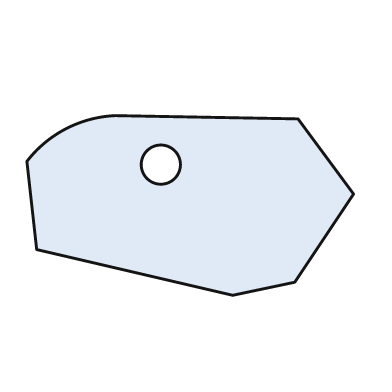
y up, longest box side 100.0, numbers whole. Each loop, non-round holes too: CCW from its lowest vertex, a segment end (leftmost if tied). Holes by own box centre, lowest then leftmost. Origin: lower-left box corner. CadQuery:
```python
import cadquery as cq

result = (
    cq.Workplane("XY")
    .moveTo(63.0, 0.0)
    .lineTo(82.0, 4.0)
    .lineTo(100.0, 31.0)
    .lineTo(83.0, 54.0)
    .lineTo(27.0, 55.0)
    .threePointArc((12.0, 51.0), (0.0, 41.0))
    .lineTo(3.0, 14.0)
    .close()
    .moveTo(41.0, 40.0)
    .circle(6.0)
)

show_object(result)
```